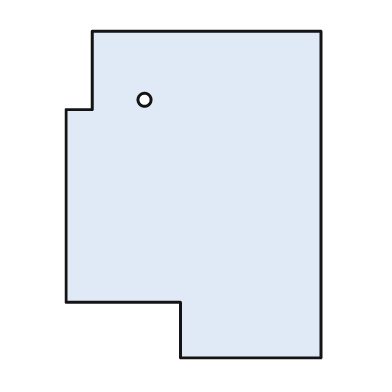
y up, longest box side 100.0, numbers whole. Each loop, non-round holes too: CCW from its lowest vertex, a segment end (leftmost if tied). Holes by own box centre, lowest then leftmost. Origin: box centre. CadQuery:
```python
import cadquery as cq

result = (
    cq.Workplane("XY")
    .moveTo(-4.0, -50.0)
    .lineTo(39.0, -50.0)
    .lineTo(39.0, 50.0)
    .lineTo(-31.0, 50.0)
    .lineTo(-31.0, 26.0)
    .lineTo(-39.0, 26.0)
    .lineTo(-39.0, -33.0)
    .lineTo(-4.0, -33.0)
    .close()
    .moveTo(-15.0, 29.0)
    .circle(2.0)
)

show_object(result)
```